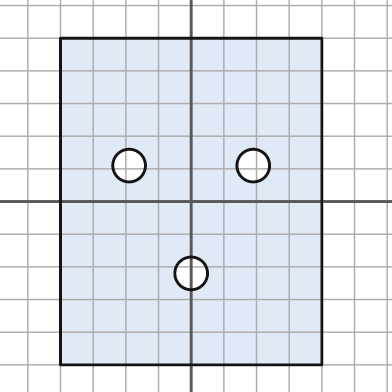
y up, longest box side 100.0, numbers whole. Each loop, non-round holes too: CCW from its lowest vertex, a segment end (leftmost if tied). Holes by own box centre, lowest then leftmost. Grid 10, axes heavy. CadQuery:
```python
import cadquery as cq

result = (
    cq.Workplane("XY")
    .moveTo(-40.0, -50.0)
    .lineTo(40.0, -50.0)
    .lineTo(40.0, 50.0)
    .lineTo(-40.0, 50.0)
    .close()
    .moveTo(0.0, -22.0)
    .circle(5.0)
    .moveTo(-19.0, 11.0)
    .circle(5.0)
    .moveTo(19.0, 11.0)
    .circle(5.0)
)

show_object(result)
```